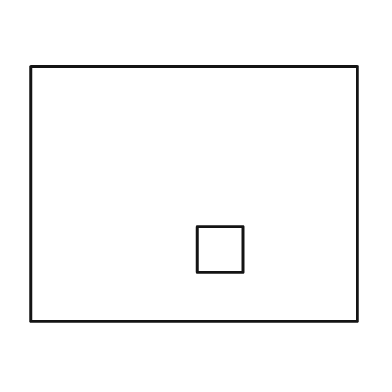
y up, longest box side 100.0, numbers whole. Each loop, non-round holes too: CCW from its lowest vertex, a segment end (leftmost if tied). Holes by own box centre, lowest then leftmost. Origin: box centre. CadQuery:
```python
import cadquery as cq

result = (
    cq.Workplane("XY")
    .moveTo(-50.0, -39.0)
    .lineTo(50.0, -39.0)
    .lineTo(50.0, 39.0)
    .lineTo(-50.0, 39.0)
    .close()
    .moveTo(1.0, -24.0)
    .lineTo(15.0, -24.0)
    .lineTo(15.0, -10.0)
    .lineTo(1.0, -10.0)
    .close()
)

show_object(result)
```